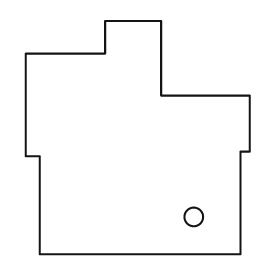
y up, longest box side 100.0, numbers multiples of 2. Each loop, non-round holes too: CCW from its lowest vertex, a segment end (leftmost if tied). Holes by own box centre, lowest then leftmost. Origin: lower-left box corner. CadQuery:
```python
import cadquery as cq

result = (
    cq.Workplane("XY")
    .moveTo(6.0, 0.0)
    .lineTo(92.0, 0.0)
    .lineTo(92.0, 44.0)
    .lineTo(96.0, 44.0)
    .lineTo(96.0, 68.0)
    .lineTo(58.0, 68.0)
    .lineTo(58.0, 100.0)
    .lineTo(34.0, 100.0)
    .lineTo(34.0, 86.0)
    .lineTo(0.0, 86.0)
    .lineTo(0.0, 42.0)
    .lineTo(6.0, 42.0)
    .close()
    .moveTo(72.0, 16.0)
    .circle(4.0)
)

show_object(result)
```